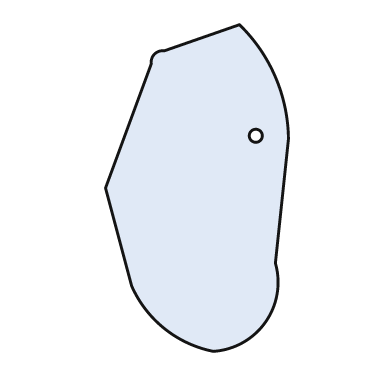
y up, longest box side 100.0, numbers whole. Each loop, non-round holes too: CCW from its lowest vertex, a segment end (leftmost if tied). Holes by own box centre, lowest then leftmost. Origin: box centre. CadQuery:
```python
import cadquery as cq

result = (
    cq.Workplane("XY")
    .moveTo(5.0, -50.0)
    .threePointArc((21.0, -41.0), (24.0, -23.0))
    .lineTo(28.0, 15.0)
    .threePointArc((24.0, 34.0), (13.0, 50.0))
    .lineTo(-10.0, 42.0)
    .threePointArc((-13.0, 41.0), (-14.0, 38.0))
    .lineTo(-28.0, 0.0)
    .lineTo(-20.0, -30.0)
    .threePointArc((-10.0, -43.0), (5.0, -50.0))
    .close()
    .moveTo(18.0, 16.0)
    .circle(2.0)
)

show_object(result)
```